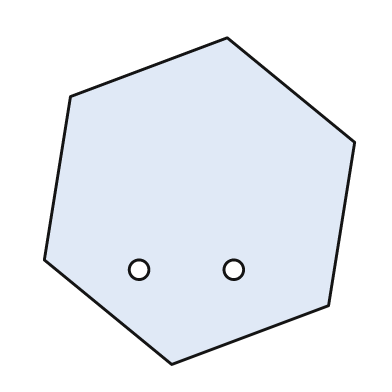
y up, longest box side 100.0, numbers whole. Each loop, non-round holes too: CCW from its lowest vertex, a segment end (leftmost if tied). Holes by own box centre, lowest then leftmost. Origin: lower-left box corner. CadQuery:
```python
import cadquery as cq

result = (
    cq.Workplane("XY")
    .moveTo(39.0, 0.0)
    .lineTo(87.0, 18.0)
    .lineTo(95.0, 68.0)
    .lineTo(56.0, 100.0)
    .lineTo(8.0, 82.0)
    .lineTo(0.0, 32.0)
    .close()
    .moveTo(29.0, 29.0)
    .circle(3.0)
    .moveTo(58.0, 29.0)
    .circle(3.0)
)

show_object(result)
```